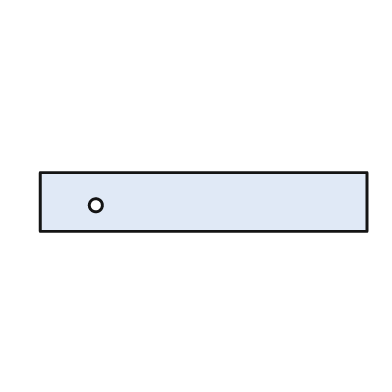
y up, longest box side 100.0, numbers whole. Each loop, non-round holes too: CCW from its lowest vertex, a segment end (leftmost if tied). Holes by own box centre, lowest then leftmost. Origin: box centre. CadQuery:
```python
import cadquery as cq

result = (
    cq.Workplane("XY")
    .moveTo(-50.0, -9.0)
    .lineTo(50.0, -9.0)
    .lineTo(50.0, 9.0)
    .lineTo(-50.0, 9.0)
    .close()
    .moveTo(-33.0, -1.0)
    .circle(2.0)
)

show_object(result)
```